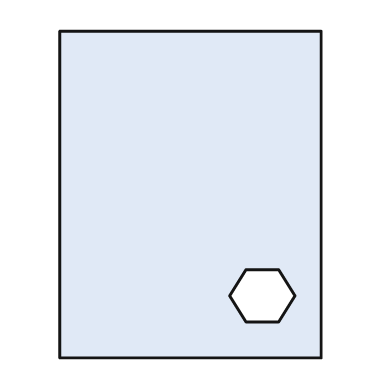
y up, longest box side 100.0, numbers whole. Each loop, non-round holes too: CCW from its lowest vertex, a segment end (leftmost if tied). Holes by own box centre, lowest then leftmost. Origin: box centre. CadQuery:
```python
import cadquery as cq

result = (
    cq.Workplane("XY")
    .moveTo(-40.0, -50.0)
    .lineTo(40.0, -50.0)
    .lineTo(40.0, 50.0)
    .lineTo(-40.0, 50.0)
    .close()
    .moveTo(17.0, -39.0)
    .lineTo(27.0, -39.0)
    .lineTo(32.0, -31.0)
    .lineTo(27.0, -23.0)
    .lineTo(17.0, -23.0)
    .lineTo(12.0, -31.0)
    .close()
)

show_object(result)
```